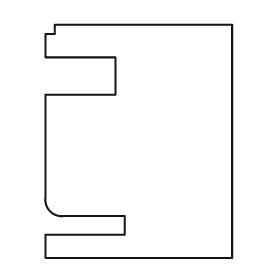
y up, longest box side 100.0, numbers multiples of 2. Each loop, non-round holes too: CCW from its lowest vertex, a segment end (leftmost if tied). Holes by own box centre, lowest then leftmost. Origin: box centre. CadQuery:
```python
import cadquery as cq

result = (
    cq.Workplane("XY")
    .moveTo(-40.0, -50.0)
    .lineTo(40.0, -50.0)
    .lineTo(40.0, 50.0)
    .lineTo(-36.0, 50.0)
    .lineTo(-36.0, 46.0)
    .lineTo(-40.0, 46.0)
    .lineTo(-40.0, 36.0)
    .lineTo(-10.0, 36.0)
    .lineTo(-10.0, 20.0)
    .lineTo(-40.0, 20.0)
    .lineTo(-40.0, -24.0)
    .threePointArc((-38.0, -30.0), (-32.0, -32.0))
    .lineTo(-6.0, -32.0)
    .lineTo(-6.0, -40.0)
    .lineTo(-40.0, -40.0)
    .close()
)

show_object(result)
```